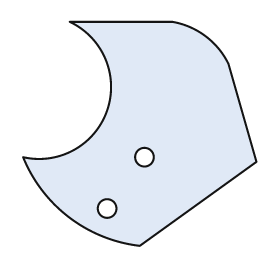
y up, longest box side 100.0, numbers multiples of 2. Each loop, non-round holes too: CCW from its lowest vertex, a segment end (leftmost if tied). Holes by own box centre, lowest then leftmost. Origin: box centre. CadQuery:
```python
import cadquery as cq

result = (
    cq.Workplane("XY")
    .moveTo(0.0, -48.0)
    .lineTo(50.0, -12.0)
    .lineTo(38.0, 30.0)
    .threePointArc((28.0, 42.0), (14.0, 48.0))
    .lineTo(-30.0, 48.0)
    .threePointArc((-14.0, 10.0), (-50.0, -10.0))
    .threePointArc((-30.0, -36.0), (0.0, -48.0))
    .close()
    .moveTo(-14.0, -32.0)
    .circle(4.0)
    .moveTo(2.0, -10.0)
    .circle(4.0)
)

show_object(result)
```